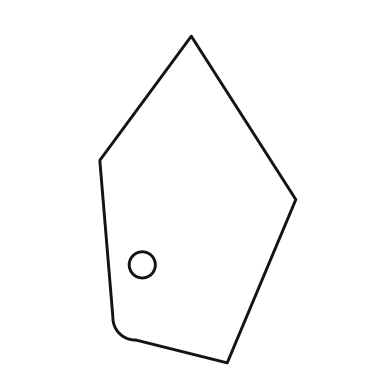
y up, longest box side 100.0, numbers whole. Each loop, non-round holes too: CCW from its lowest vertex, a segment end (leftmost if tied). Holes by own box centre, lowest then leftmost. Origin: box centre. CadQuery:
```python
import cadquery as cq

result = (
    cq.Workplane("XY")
    .moveTo(9.0, -50.0)
    .lineTo(30.0, 0.0)
    .lineTo(-2.0, 50.0)
    .lineTo(-30.0, 12.0)
    .lineTo(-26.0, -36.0)
    .threePointArc((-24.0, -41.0), (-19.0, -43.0))
    .close()
    .moveTo(-17.0, -20.0)
    .circle(4.0)
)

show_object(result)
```